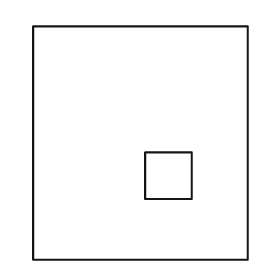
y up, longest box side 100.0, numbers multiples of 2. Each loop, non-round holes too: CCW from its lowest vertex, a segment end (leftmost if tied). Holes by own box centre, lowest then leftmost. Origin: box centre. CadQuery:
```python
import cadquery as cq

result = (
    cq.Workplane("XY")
    .moveTo(-46.0, -50.0)
    .lineTo(46.0, -50.0)
    .lineTo(46.0, 50.0)
    .lineTo(-46.0, 50.0)
    .close()
    .moveTo(2.0, -24.0)
    .lineTo(22.0, -24.0)
    .lineTo(22.0, -4.0)
    .lineTo(2.0, -4.0)
    .close()
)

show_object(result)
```